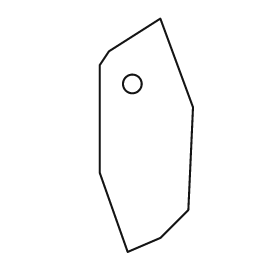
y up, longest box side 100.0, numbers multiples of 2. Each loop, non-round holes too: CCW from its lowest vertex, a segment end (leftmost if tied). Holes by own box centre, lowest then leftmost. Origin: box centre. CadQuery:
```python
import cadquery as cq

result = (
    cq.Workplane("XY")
    .moveTo(-8.0, -50.0)
    .lineTo(6.0, -44.0)
    .lineTo(18.0, -32.0)
    .lineTo(20.0, 12.0)
    .lineTo(6.0, 50.0)
    .lineTo(-16.0, 36.0)
    .lineTo(-20.0, 30.0)
    .lineTo(-20.0, -16.0)
    .close()
    .moveTo(-6.0, 22.0)
    .circle(4.0)
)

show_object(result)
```